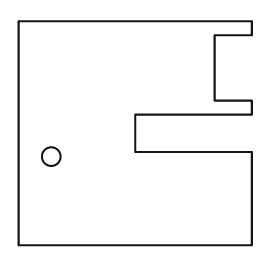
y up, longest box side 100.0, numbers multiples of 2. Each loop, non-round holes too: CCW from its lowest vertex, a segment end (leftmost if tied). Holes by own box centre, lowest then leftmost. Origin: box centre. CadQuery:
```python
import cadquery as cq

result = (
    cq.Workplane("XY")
    .moveTo(-50.0, -48.0)
    .lineTo(50.0, -48.0)
    .lineTo(50.0, -8.0)
    .lineTo(0.0, -8.0)
    .lineTo(0.0, 8.0)
    .lineTo(50.0, 8.0)
    .lineTo(50.0, 14.0)
    .lineTo(34.0, 14.0)
    .lineTo(34.0, 42.0)
    .lineTo(50.0, 42.0)
    .lineTo(50.0, 48.0)
    .lineTo(-50.0, 48.0)
    .close()
    .moveTo(-36.0, -10.0)
    .circle(4.0)
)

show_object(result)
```